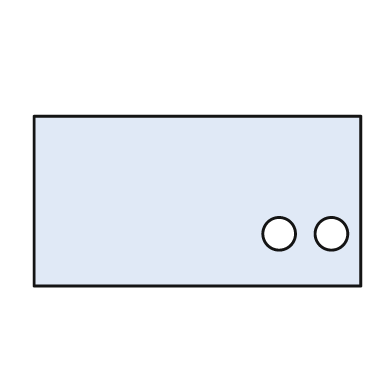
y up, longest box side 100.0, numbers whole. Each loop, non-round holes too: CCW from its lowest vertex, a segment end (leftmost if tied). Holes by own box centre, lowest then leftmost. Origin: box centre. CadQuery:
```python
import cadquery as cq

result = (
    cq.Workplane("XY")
    .moveTo(-50.0, -26.0)
    .lineTo(50.0, -26.0)
    .lineTo(50.0, 26.0)
    .lineTo(-50.0, 26.0)
    .close()
    .moveTo(25.0, -10.0)
    .circle(5.0)
    .moveTo(41.0, -10.0)
    .circle(5.0)
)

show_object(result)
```